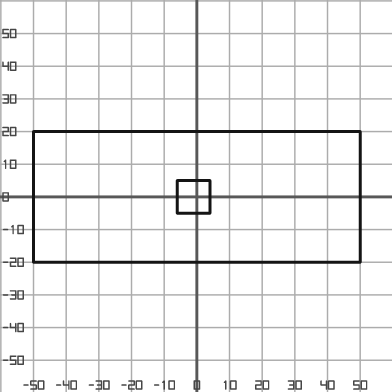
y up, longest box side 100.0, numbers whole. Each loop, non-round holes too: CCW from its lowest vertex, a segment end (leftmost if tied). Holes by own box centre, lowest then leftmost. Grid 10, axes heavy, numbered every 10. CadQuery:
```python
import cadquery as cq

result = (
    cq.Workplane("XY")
    .moveTo(-50.0, -20.0)
    .lineTo(50.0, -20.0)
    .lineTo(50.0, 20.0)
    .lineTo(-50.0, 20.0)
    .close()
    .moveTo(-6.0, -5.0)
    .lineTo(4.0, -5.0)
    .lineTo(4.0, 5.0)
    .lineTo(-6.0, 5.0)
    .close()
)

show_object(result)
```